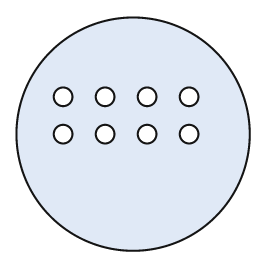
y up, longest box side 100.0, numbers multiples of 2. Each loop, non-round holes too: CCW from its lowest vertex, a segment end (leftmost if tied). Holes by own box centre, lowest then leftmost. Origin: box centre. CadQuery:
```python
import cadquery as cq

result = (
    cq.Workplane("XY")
    .moveTo(0.0, 0.0)
    .circle(50.0)
    .moveTo(-30.0, 0.0)
    .circle(4.0)
    .moveTo(-12.0, 0.0)
    .circle(4.0)
    .moveTo(6.0, 0.0)
    .circle(4.0)
    .moveTo(24.0, 0.0)
    .circle(4.0)
    .moveTo(-30.0, 16.0)
    .circle(4.0)
    .moveTo(-12.0, 16.0)
    .circle(4.0)
    .moveTo(6.0, 16.0)
    .circle(4.0)
    .moveTo(24.0, 16.0)
    .circle(4.0)
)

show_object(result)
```